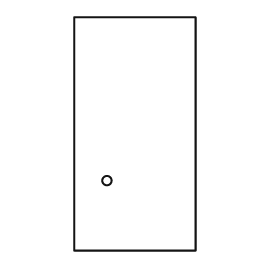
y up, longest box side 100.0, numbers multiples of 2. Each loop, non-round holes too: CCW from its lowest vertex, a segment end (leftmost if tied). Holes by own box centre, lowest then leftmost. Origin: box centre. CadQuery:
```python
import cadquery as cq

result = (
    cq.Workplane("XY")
    .moveTo(-26.0, -50.0)
    .lineTo(26.0, -50.0)
    .lineTo(26.0, 50.0)
    .lineTo(-26.0, 50.0)
    .close()
    .moveTo(-12.0, -20.0)
    .circle(2.0)
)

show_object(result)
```